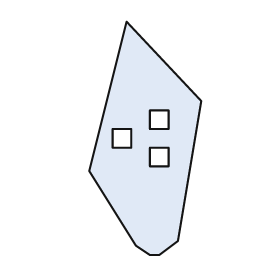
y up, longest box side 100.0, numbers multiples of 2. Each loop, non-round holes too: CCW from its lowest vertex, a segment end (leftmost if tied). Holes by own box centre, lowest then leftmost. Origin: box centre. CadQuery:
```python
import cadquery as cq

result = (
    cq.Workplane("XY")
    .moveTo(2.0, -50.0)
    .lineTo(6.0, -50.0)
    .lineTo(14.0, -44.0)
    .lineTo(24.0, 16.0)
    .lineTo(-8.0, 50.0)
    .lineTo(-24.0, -14.0)
    .lineTo(-4.0, -46.0)
    .close()
    .moveTo(2.0, -12.0)
    .lineTo(10.0, -12.0)
    .lineTo(10.0, -4.0)
    .lineTo(2.0, -4.0)
    .close()
    .moveTo(-14.0, -4.0)
    .lineTo(-6.0, -4.0)
    .lineTo(-6.0, 4.0)
    .lineTo(-14.0, 4.0)
    .close()
    .moveTo(2.0, 4.0)
    .lineTo(10.0, 4.0)
    .lineTo(10.0, 12.0)
    .lineTo(2.0, 12.0)
    .close()
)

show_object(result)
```